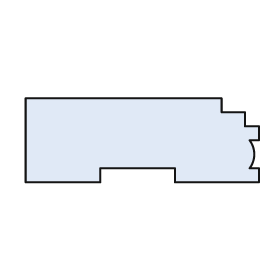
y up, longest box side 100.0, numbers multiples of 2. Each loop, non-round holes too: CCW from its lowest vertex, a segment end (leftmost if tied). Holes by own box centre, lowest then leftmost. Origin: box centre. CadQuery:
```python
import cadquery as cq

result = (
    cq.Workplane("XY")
    .moveTo(-50.0, -18.0)
    .lineTo(-18.0, -18.0)
    .lineTo(-18.0, -12.0)
    .lineTo(14.0, -12.0)
    .lineTo(14.0, -18.0)
    .lineTo(50.0, -18.0)
    .lineTo(50.0, -12.0)
    .lineTo(46.0, -12.0)
    .threePointArc((48.0, -6.0), (46.0, 0.0))
    .lineTo(50.0, 0.0)
    .lineTo(50.0, 6.0)
    .lineTo(44.0, 6.0)
    .lineTo(44.0, 12.0)
    .lineTo(34.0, 12.0)
    .lineTo(34.0, 18.0)
    .lineTo(-50.0, 18.0)
    .close()
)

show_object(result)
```